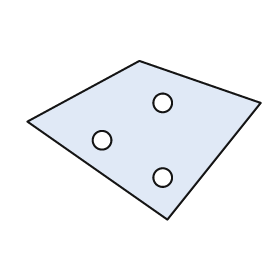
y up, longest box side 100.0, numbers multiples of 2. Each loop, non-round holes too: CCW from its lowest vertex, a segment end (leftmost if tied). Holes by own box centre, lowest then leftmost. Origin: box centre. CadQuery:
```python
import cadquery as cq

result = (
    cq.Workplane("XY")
    .moveTo(10.0, -34.0)
    .lineTo(50.0, 16.0)
    .lineTo(-2.0, 34.0)
    .lineTo(-50.0, 8.0)
    .close()
    .moveTo(8.0, -16.0)
    .circle(4.0)
    .moveTo(-18.0, 0.0)
    .circle(4.0)
    .moveTo(8.0, 16.0)
    .circle(4.0)
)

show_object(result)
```